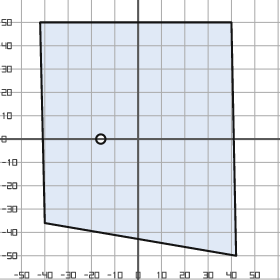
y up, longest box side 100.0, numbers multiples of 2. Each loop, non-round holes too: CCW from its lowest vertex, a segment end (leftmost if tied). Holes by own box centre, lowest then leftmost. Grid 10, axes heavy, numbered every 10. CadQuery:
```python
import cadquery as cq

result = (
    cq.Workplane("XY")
    .moveTo(42.0, -50.0)
    .lineTo(40.0, 50.0)
    .lineTo(-42.0, 50.0)
    .lineTo(-40.0, -36.0)
    .close()
    .moveTo(-16.0, 0.0)
    .circle(2.0)
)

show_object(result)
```